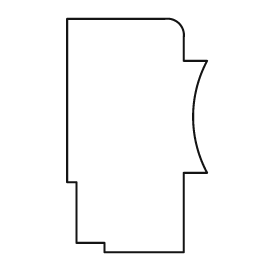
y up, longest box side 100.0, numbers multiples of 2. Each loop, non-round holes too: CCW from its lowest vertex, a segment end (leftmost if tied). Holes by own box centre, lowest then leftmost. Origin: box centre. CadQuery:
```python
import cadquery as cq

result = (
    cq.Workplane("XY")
    .moveTo(-14.0, -50.0)
    .lineTo(20.0, -50.0)
    .lineTo(20.0, -16.0)
    .lineTo(30.0, -16.0)
    .threePointArc((24.0, 8.0), (30.0, 32.0))
    .lineTo(20.0, 32.0)
    .lineTo(20.0, 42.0)
    .threePointArc((18.0, 48.0), (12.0, 50.0))
    .lineTo(-30.0, 50.0)
    .lineTo(-30.0, -20.0)
    .lineTo(-26.0, -20.0)
    .lineTo(-26.0, -46.0)
    .lineTo(-14.0, -46.0)
    .close()
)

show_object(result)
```